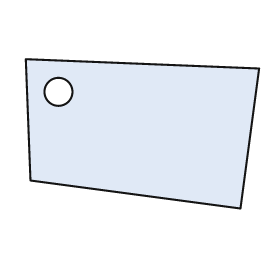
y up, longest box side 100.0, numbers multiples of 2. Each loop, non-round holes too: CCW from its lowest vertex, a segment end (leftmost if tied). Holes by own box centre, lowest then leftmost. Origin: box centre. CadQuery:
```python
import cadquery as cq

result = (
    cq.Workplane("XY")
    .moveTo(42.0, -32.0)
    .lineTo(50.0, 28.0)
    .lineTo(-50.0, 32.0)
    .lineTo(-48.0, -20.0)
    .close()
    .moveTo(-36.0, 18.0)
    .circle(6.0)
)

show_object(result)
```